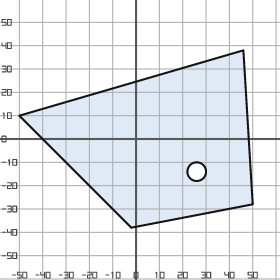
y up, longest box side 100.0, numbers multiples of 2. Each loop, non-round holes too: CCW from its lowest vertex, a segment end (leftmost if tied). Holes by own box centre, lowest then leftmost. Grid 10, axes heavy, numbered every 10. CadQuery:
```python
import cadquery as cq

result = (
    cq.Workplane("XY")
    .moveTo(-2.0, -38.0)
    .lineTo(50.0, -28.0)
    .lineTo(46.0, 38.0)
    .lineTo(-50.0, 10.0)
    .close()
    .moveTo(26.0, -14.0)
    .circle(4.0)
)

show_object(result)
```